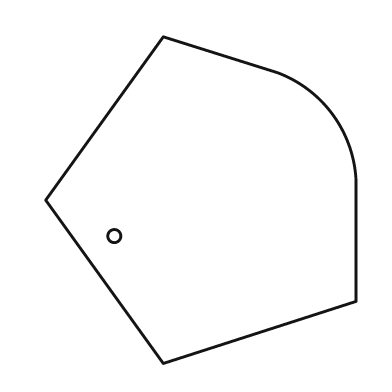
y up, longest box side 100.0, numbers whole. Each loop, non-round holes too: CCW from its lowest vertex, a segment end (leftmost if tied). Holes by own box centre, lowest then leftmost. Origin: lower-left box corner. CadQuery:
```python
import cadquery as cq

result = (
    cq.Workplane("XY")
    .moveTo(36.0, 0.0)
    .lineTo(95.0, 19.0)
    .lineTo(95.0, 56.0)
    .threePointArc((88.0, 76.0), (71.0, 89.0))
    .lineTo(36.0, 100.0)
    .lineTo(0.0, 50.0)
    .close()
    .moveTo(21.0, 39.0)
    .circle(2.0)
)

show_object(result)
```